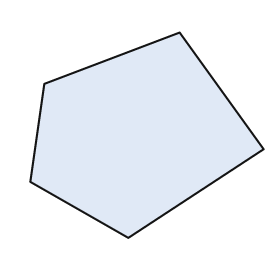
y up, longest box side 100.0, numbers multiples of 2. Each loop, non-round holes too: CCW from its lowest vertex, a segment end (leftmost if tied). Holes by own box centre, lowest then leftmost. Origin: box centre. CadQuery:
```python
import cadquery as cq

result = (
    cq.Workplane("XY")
    .moveTo(-8.0, -44.0)
    .lineTo(50.0, -6.0)
    .lineTo(14.0, 44.0)
    .lineTo(-44.0, 22.0)
    .lineTo(-50.0, -20.0)
    .close()
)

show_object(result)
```